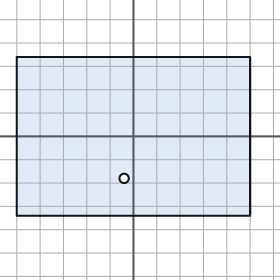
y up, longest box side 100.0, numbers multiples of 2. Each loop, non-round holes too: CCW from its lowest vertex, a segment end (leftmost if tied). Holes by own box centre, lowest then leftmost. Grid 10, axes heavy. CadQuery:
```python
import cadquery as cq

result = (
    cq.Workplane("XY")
    .moveTo(-50.0, -34.0)
    .lineTo(50.0, -34.0)
    .lineTo(50.0, 34.0)
    .lineTo(-50.0, 34.0)
    .close()
    .moveTo(-4.0, -18.0)
    .circle(2.0)
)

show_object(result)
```